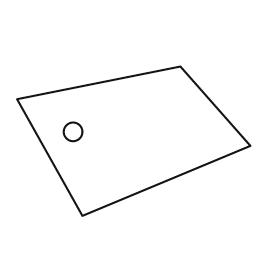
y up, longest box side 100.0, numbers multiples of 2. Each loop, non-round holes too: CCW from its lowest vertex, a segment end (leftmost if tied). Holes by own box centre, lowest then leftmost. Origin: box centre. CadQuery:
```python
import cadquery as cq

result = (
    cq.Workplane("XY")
    .moveTo(-22.0, -32.0)
    .lineTo(50.0, -2.0)
    .lineTo(20.0, 32.0)
    .lineTo(-50.0, 18.0)
    .close()
    .moveTo(-26.0, 4.0)
    .circle(4.0)
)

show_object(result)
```